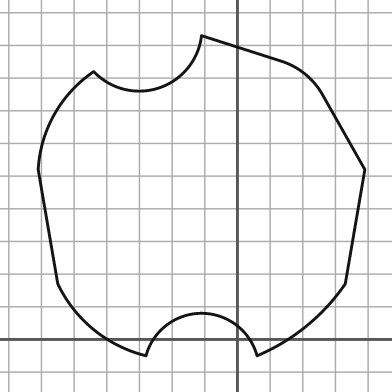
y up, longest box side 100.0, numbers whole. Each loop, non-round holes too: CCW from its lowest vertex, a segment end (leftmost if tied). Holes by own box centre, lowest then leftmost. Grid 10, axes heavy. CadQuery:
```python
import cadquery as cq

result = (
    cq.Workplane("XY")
    .moveTo(-28.0, -5.0)
    .threePointArc((-11.0, 8.0), (6.0, -5.0))
    .threePointArc((21.0, 4.0), (33.0, 17.0))
    .lineTo(39.0, 52.0)
    .lineTo(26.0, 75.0)
    .threePointArc((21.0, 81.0), (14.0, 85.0))
    .lineTo(-11.0, 93.0)
    .threePointArc((-24.0, 77.0), (-44.0, 82.0))
    .threePointArc((-56.0, 69.0), (-61.0, 52.0))
    .lineTo(-55.0, 17.0)
    .threePointArc((-44.0, 3.0), (-28.0, -5.0))
    .close()
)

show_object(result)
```